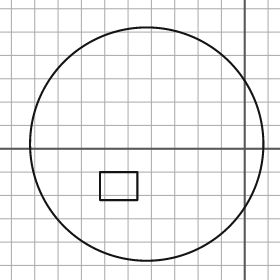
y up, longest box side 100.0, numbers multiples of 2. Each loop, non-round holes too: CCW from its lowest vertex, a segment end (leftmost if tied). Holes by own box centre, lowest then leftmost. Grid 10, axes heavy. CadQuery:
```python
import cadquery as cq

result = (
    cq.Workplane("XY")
    .moveTo(-42.0, 2.0)
    .circle(50.0)
    .moveTo(-62.0, -22.0)
    .lineTo(-46.0, -22.0)
    .lineTo(-46.0, -10.0)
    .lineTo(-62.0, -10.0)
    .close()
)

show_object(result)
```